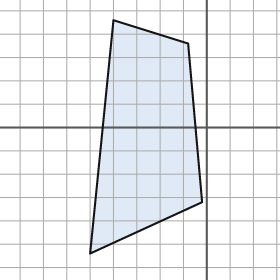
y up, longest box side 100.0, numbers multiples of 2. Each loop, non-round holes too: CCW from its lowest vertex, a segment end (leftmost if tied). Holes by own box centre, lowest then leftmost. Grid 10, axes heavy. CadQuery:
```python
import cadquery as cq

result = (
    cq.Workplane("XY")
    .moveTo(-50.0, -54.0)
    .lineTo(-2.0, -32.0)
    .lineTo(-8.0, 36.0)
    .lineTo(-40.0, 46.0)
    .close()
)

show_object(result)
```